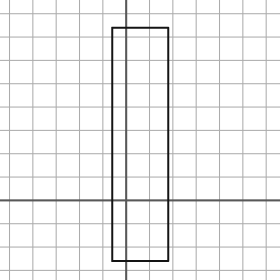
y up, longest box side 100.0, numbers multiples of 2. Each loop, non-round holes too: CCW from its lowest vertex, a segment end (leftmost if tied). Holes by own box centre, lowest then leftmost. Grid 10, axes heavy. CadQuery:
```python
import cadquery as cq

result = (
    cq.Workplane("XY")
    .moveTo(-6.0, -26.0)
    .lineTo(18.0, -26.0)
    .lineTo(18.0, 74.0)
    .lineTo(-6.0, 74.0)
    .close()
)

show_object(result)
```